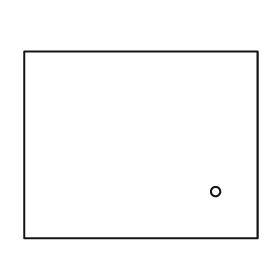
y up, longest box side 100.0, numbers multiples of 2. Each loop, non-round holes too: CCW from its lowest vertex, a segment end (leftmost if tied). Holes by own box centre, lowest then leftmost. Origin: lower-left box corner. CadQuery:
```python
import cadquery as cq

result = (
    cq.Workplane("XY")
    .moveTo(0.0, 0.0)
    .lineTo(100.0, 0.0)
    .lineTo(100.0, 80.0)
    .lineTo(0.0, 80.0)
    .close()
    .moveTo(82.0, 20.0)
    .circle(2.0)
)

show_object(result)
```